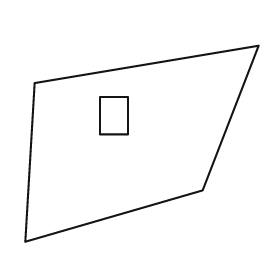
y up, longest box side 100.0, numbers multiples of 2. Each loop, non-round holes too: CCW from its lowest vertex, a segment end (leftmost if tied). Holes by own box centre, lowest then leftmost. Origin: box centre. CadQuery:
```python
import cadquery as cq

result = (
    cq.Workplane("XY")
    .moveTo(-50.0, -42.0)
    .lineTo(26.0, -20.0)
    .lineTo(50.0, 42.0)
    .lineTo(-46.0, 26.0)
    .close()
    .moveTo(-18.0, 4.0)
    .lineTo(-6.0, 4.0)
    .lineTo(-6.0, 20.0)
    .lineTo(-18.0, 20.0)
    .close()
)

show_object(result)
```